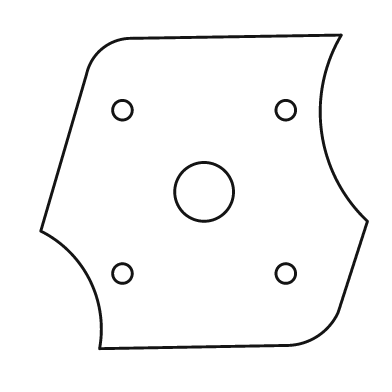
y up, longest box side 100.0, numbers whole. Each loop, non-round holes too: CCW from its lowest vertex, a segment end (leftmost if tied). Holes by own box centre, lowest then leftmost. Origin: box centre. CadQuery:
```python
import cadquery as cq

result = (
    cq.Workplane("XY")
    .moveTo(-32.0, -48.0)
    .lineTo(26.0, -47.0)
    .threePointArc((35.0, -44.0), (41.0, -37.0))
    .lineTo(50.0, -9.0)
    .threePointArc((36.0, 18.0), (42.0, 48.0))
    .lineTo(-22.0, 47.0)
    .threePointArc((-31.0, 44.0), (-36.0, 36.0))
    .lineTo(-50.0, -12.0)
    .threePointArc((-35.0, -27.0), (-32.0, -48.0))
    .close()
    .moveTo(-25.0, -25.0)
    .circle(3.0)
    .moveTo(25.0, -25.0)
    .circle(3.0)
    .moveTo(0.0, 0.0)
    .circle(9.0)
    .moveTo(-25.0, 25.0)
    .circle(3.0)
    .moveTo(25.0, 25.0)
    .circle(3.0)
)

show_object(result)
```